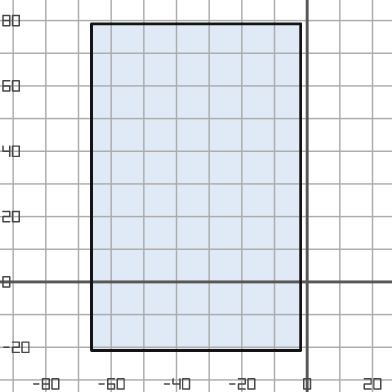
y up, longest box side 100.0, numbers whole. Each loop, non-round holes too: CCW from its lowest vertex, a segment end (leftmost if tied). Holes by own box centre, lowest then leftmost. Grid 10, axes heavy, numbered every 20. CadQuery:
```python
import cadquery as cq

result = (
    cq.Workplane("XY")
    .moveTo(-66.0, -21.0)
    .lineTo(-2.0, -21.0)
    .lineTo(-2.0, 79.0)
    .lineTo(-66.0, 79.0)
    .close()
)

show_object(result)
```